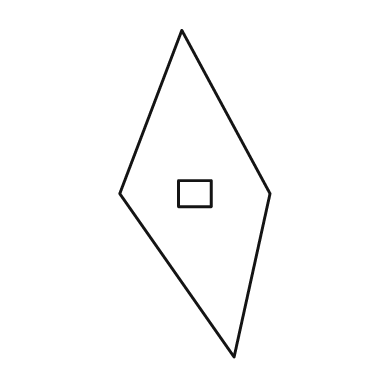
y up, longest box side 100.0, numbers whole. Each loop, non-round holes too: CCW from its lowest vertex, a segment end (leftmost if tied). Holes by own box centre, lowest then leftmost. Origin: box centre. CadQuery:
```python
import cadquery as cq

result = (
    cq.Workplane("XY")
    .moveTo(12.0, -50.0)
    .lineTo(23.0, 0.0)
    .lineTo(-4.0, 50.0)
    .lineTo(-23.0, 0.0)
    .close()
    .moveTo(-5.0, -4.0)
    .lineTo(5.0, -4.0)
    .lineTo(5.0, 4.0)
    .lineTo(-5.0, 4.0)
    .close()
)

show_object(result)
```